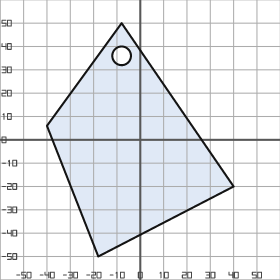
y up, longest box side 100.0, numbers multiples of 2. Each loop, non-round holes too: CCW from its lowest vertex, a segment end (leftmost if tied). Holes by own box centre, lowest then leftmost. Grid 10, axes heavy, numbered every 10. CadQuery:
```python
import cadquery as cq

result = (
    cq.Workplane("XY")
    .moveTo(-18.0, -50.0)
    .lineTo(40.0, -20.0)
    .lineTo(-8.0, 50.0)
    .lineTo(-40.0, 6.0)
    .close()
    .moveTo(-8.0, 36.0)
    .circle(4.0)
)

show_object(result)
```